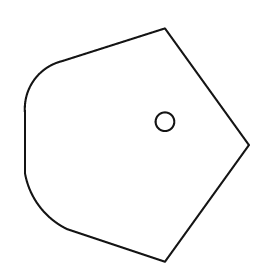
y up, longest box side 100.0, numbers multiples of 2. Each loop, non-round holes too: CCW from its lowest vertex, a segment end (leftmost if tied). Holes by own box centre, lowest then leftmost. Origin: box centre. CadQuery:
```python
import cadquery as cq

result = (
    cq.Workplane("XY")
    .moveTo(12.0, -50.0)
    .lineTo(48.0, 0.0)
    .lineTo(12.0, 50.0)
    .lineTo(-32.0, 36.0)
    .threePointArc((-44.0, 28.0), (-48.0, 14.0))
    .lineTo(-48.0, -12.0)
    .threePointArc((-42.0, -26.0), (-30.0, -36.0))
    .close()
    .moveTo(12.0, 10.0)
    .circle(4.0)
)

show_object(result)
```